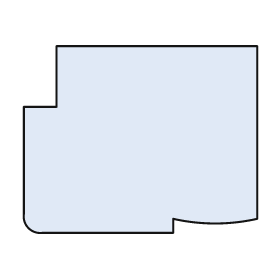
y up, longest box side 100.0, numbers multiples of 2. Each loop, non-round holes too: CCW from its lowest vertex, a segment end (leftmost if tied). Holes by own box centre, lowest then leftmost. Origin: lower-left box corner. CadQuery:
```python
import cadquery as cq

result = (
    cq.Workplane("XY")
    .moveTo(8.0, 0.0)
    .lineTo(64.0, 0.0)
    .lineTo(64.0, 6.0)
    .threePointArc((82.0, 4.0), (100.0, 6.0))
    .lineTo(100.0, 80.0)
    .lineTo(14.0, 80.0)
    .lineTo(14.0, 54.0)
    .lineTo(0.0, 54.0)
    .lineTo(0.0, 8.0)
    .threePointArc((2.0, 2.0), (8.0, 0.0))
    .close()
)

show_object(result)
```